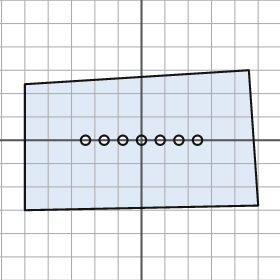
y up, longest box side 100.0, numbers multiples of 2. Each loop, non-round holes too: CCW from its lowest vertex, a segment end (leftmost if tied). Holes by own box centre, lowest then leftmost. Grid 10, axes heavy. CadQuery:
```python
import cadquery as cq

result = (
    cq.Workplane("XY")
    .moveTo(-50.0, -30.0)
    .lineTo(50.0, -28.0)
    .lineTo(46.0, 30.0)
    .lineTo(-50.0, 24.0)
    .close()
    .moveTo(-24.0, 0.0)
    .circle(2.0)
    .moveTo(-16.0, 0.0)
    .circle(2.0)
    .moveTo(-8.0, 0.0)
    .circle(2.0)
    .moveTo(0.0, 0.0)
    .circle(2.0)
    .moveTo(8.0, 0.0)
    .circle(2.0)
    .moveTo(16.0, 0.0)
    .circle(2.0)
    .moveTo(24.0, 0.0)
    .circle(2.0)
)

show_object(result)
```